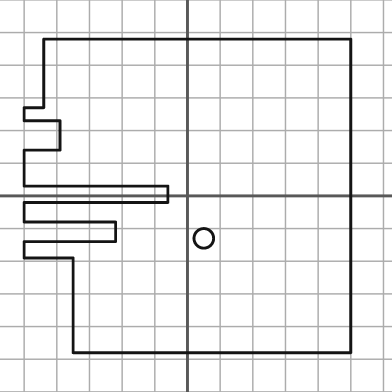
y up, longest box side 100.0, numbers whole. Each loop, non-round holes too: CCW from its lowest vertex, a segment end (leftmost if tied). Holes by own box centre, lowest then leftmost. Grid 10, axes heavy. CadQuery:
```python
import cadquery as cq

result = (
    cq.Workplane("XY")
    .moveTo(-35.0, -48.0)
    .lineTo(50.0, -48.0)
    .lineTo(50.0, 48.0)
    .lineTo(-44.0, 48.0)
    .lineTo(-44.0, 27.0)
    .lineTo(-50.0, 27.0)
    .lineTo(-50.0, 23.0)
    .lineTo(-39.0, 23.0)
    .lineTo(-39.0, 14.0)
    .lineTo(-50.0, 14.0)
    .lineTo(-50.0, 3.0)
    .lineTo(-6.0, 3.0)
    .lineTo(-6.0, -2.0)
    .lineTo(-50.0, -2.0)
    .lineTo(-50.0, -8.0)
    .lineTo(-22.0, -8.0)
    .lineTo(-22.0, -14.0)
    .lineTo(-50.0, -14.0)
    .lineTo(-50.0, -19.0)
    .lineTo(-35.0, -19.0)
    .close()
    .moveTo(5.0, -13.0)
    .circle(3.0)
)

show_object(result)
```